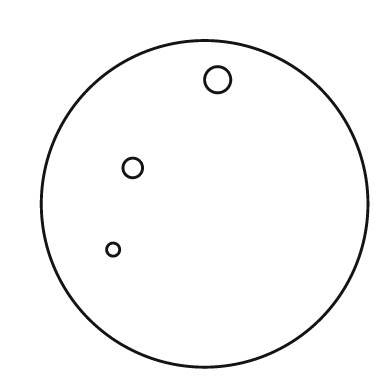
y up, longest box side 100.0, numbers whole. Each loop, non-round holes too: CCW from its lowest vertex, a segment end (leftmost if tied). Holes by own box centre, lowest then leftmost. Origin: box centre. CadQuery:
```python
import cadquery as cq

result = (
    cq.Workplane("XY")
    .moveTo(0.0, 0.0)
    .circle(50.0)
    .moveTo(-28.0, -14.0)
    .circle(2.0)
    .moveTo(-22.0, 11.0)
    .circle(3.0)
    .moveTo(4.0, 38.0)
    .circle(4.0)
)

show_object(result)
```